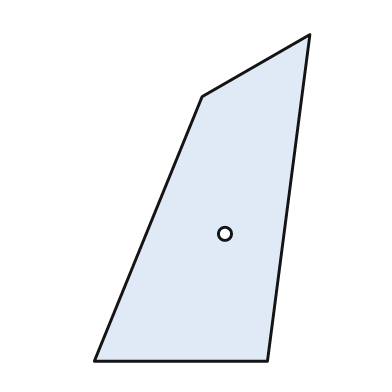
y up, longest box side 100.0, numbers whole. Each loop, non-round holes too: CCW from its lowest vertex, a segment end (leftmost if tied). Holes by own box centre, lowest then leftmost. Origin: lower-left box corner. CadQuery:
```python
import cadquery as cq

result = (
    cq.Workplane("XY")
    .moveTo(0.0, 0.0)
    .lineTo(53.0, 0.0)
    .lineTo(66.0, 100.0)
    .lineTo(33.0, 81.0)
    .close()
    .moveTo(40.0, 39.0)
    .circle(2.0)
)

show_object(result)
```